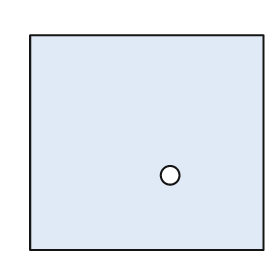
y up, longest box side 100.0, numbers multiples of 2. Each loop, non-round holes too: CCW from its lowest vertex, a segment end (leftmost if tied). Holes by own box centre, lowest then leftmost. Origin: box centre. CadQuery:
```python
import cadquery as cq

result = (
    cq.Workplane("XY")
    .moveTo(-50.0, -46.0)
    .lineTo(50.0, -46.0)
    .lineTo(50.0, 46.0)
    .lineTo(-50.0, 46.0)
    .close()
    .moveTo(10.0, -14.0)
    .circle(4.0)
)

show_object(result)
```